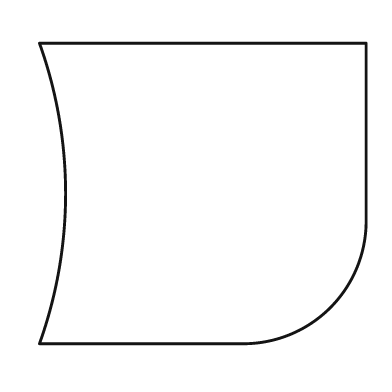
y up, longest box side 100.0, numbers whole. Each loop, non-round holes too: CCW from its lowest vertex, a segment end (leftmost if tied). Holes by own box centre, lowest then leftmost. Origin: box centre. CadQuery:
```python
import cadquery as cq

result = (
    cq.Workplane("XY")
    .moveTo(-50.0, -46.0)
    .lineTo(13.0, -46.0)
    .threePointArc((39.0, -35.0), (50.0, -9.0))
    .lineTo(50.0, 46.0)
    .lineTo(-50.0, 46.0)
    .threePointArc((-42.0, 0.0), (-50.0, -46.0))
    .close()
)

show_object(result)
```